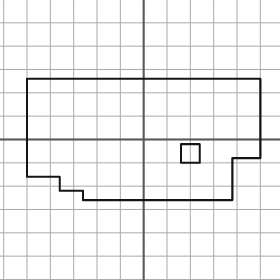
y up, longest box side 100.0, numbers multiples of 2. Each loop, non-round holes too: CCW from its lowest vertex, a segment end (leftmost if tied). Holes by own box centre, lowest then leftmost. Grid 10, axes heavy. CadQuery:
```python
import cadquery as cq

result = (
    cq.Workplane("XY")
    .moveTo(-26.0, -26.0)
    .lineTo(38.0, -26.0)
    .lineTo(38.0, -8.0)
    .lineTo(50.0, -8.0)
    .lineTo(50.0, 26.0)
    .lineTo(-50.0, 26.0)
    .lineTo(-50.0, -16.0)
    .lineTo(-36.0, -16.0)
    .lineTo(-36.0, -22.0)
    .lineTo(-26.0, -22.0)
    .close()
    .moveTo(16.0, -10.0)
    .lineTo(24.0, -10.0)
    .lineTo(24.0, -2.0)
    .lineTo(16.0, -2.0)
    .close()
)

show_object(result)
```